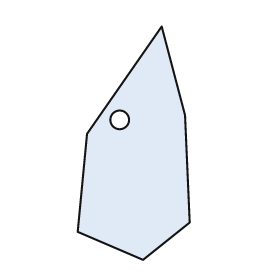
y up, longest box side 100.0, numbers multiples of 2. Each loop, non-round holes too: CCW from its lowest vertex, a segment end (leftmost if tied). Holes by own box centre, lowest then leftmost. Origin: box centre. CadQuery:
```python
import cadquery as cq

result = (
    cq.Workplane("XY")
    .moveTo(4.0, -50.0)
    .lineTo(24.0, -34.0)
    .lineTo(22.0, 12.0)
    .lineTo(12.0, 50.0)
    .lineTo(-20.0, 4.0)
    .lineTo(-24.0, -38.0)
    .close()
    .moveTo(-6.0, 10.0)
    .circle(4.0)
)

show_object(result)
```